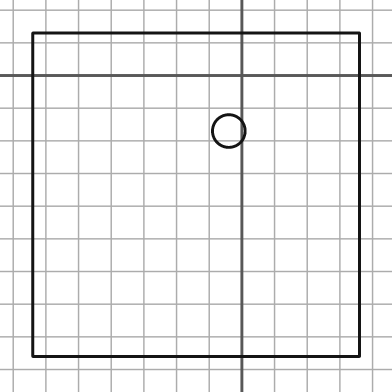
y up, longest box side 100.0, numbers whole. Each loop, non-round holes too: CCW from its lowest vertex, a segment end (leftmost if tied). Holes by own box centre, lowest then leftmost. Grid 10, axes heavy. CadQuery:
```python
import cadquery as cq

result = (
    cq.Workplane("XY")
    .moveTo(-64.0, -86.0)
    .lineTo(36.0, -86.0)
    .lineTo(36.0, 13.0)
    .lineTo(-64.0, 13.0)
    .close()
    .moveTo(-4.0, -17.0)
    .circle(5.0)
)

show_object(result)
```